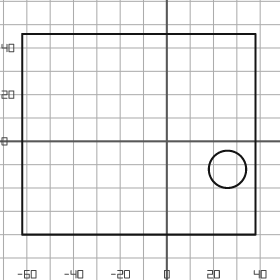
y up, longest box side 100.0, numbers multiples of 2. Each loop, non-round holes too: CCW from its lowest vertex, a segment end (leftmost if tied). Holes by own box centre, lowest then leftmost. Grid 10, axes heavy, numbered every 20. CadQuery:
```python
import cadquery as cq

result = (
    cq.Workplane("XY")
    .moveTo(-62.0, -40.0)
    .lineTo(38.0, -40.0)
    .lineTo(38.0, 46.0)
    .lineTo(-62.0, 46.0)
    .close()
    .moveTo(26.0, -12.0)
    .circle(8.0)
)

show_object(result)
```